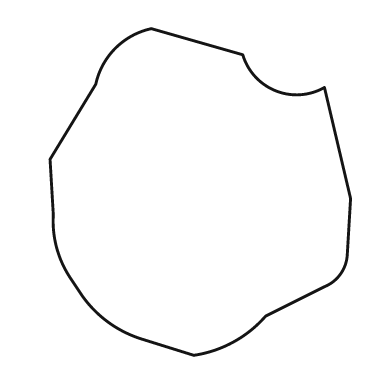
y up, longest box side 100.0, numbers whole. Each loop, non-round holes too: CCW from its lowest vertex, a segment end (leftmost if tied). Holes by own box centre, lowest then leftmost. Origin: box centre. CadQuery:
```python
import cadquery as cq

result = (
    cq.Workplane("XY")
    .moveTo(-2.0, -50.0)
    .threePointArc((10.0, -46.0), (20.0, -38.0))
    .lineTo(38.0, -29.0)
    .threePointArc((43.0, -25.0), (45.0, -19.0))
    .lineTo(46.0, -2.0)
    .lineTo(38.0, 32.0)
    .threePointArc((23.0, 31.0), (13.0, 42.0))
    .lineTo(-15.0, 50.0)
    .threePointArc((-26.0, 44.0), (-32.0, 33.0))
    .lineTo(-46.0, 10.0)
    .lineTo(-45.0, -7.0)
    .threePointArc((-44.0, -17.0), (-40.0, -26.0))
    .lineTo(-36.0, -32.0)
    .threePointArc((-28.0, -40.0), (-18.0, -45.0))
    .close()
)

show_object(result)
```